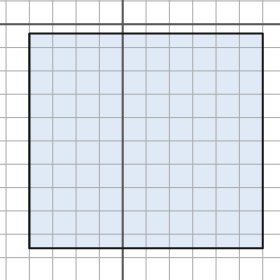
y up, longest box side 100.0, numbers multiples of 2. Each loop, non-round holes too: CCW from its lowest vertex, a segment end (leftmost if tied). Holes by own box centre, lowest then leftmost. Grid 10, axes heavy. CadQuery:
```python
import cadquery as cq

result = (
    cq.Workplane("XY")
    .moveTo(-40.0, -96.0)
    .lineTo(60.0, -96.0)
    .lineTo(60.0, -4.0)
    .lineTo(-40.0, -4.0)
    .close()
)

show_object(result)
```